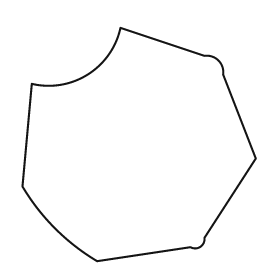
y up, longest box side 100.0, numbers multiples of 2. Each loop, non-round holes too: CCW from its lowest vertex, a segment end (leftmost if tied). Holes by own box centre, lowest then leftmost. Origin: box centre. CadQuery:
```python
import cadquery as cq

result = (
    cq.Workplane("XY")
    .moveTo(-18.0, -50.0)
    .lineTo(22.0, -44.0)
    .threePointArc((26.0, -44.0), (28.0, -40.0))
    .lineTo(50.0, -6.0)
    .lineTo(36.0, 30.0)
    .threePointArc((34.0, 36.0), (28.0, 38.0))
    .lineTo(-8.0, 50.0)
    .threePointArc((-22.0, 30.0), (-46.0, 26.0))
    .lineTo(-50.0, -18.0)
    .threePointArc((-36.0, -36.0), (-18.0, -50.0))
    .close()
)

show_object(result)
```